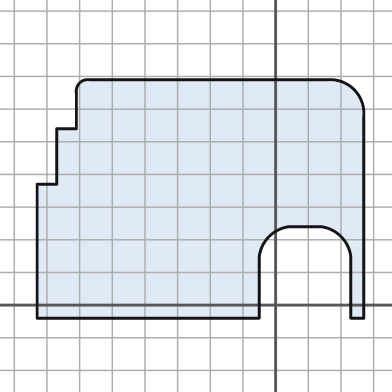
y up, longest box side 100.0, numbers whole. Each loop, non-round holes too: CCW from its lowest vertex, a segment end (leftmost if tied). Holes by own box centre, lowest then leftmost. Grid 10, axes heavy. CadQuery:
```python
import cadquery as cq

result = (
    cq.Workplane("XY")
    .moveTo(-73.0, -4.0)
    .lineTo(-5.0, -4.0)
    .lineTo(-5.0, 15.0)
    .threePointArc((-2.0, 21.0), (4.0, 24.0))
    .lineTo(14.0, 24.0)
    .threePointArc((20.0, 21.0), (23.0, 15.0))
    .lineTo(23.0, -4.0)
    .lineTo(27.0, -4.0)
    .lineTo(27.0, 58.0)
    .threePointArc((24.0, 66.0), (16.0, 69.0))
    .lineTo(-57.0, 69.0)
    .threePointArc((-60.0, 68.0), (-61.0, 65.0))
    .lineTo(-61.0, 54.0)
    .lineTo(-67.0, 54.0)
    .lineTo(-67.0, 37.0)
    .lineTo(-73.0, 37.0)
    .close()
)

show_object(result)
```